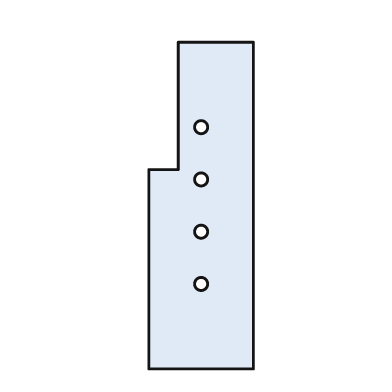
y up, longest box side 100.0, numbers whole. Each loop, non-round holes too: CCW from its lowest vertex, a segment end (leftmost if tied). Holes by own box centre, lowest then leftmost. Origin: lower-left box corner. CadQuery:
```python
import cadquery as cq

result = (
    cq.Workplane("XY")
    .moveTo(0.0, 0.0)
    .lineTo(32.0, 0.0)
    .lineTo(32.0, 100.0)
    .lineTo(9.0, 100.0)
    .lineTo(9.0, 61.0)
    .lineTo(0.0, 61.0)
    .close()
    .moveTo(16.0, 26.0)
    .circle(2.0)
    .moveTo(16.0, 42.0)
    .circle(2.0)
    .moveTo(16.0, 58.0)
    .circle(2.0)
    .moveTo(16.0, 74.0)
    .circle(2.0)
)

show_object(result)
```